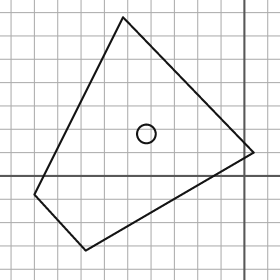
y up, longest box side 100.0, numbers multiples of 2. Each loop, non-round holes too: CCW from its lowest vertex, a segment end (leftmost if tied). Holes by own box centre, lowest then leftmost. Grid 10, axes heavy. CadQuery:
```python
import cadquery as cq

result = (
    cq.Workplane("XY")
    .moveTo(-68.0, -32.0)
    .lineTo(4.0, 10.0)
    .lineTo(-52.0, 68.0)
    .lineTo(-90.0, -8.0)
    .close()
    .moveTo(-42.0, 18.0)
    .circle(4.0)
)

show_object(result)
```